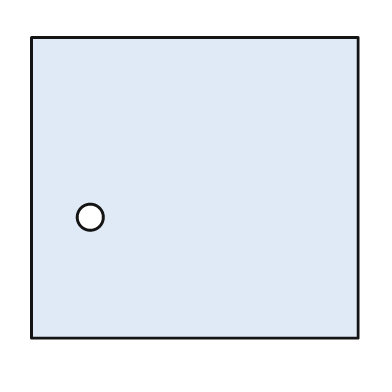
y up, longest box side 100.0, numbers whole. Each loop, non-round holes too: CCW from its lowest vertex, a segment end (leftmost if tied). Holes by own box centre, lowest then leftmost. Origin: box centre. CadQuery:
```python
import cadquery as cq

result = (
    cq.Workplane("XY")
    .moveTo(-50.0, -46.0)
    .lineTo(50.0, -46.0)
    .lineTo(50.0, 46.0)
    .lineTo(-50.0, 46.0)
    .close()
    .moveTo(-32.0, -9.0)
    .circle(4.0)
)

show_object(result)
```